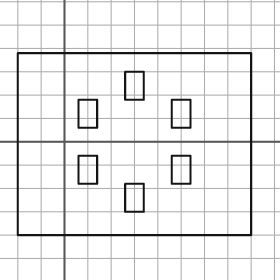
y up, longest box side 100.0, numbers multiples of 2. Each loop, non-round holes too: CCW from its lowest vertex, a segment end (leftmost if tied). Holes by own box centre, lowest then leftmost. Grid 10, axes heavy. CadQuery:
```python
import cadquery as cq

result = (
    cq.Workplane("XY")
    .moveTo(-20.0, -40.0)
    .lineTo(80.0, -40.0)
    .lineTo(80.0, 38.0)
    .lineTo(-20.0, 38.0)
    .close()
    .moveTo(26.0, -30.0)
    .lineTo(34.0, -30.0)
    .lineTo(34.0, -18.0)
    .lineTo(26.0, -18.0)
    .close()
    .moveTo(6.0, -18.0)
    .lineTo(14.0, -18.0)
    .lineTo(14.0, -6.0)
    .lineTo(6.0, -6.0)
    .close()
    .moveTo(46.0, -18.0)
    .lineTo(54.0, -18.0)
    .lineTo(54.0, -6.0)
    .lineTo(46.0, -6.0)
    .close()
    .moveTo(6.0, 6.0)
    .lineTo(14.0, 6.0)
    .lineTo(14.0, 18.0)
    .lineTo(6.0, 18.0)
    .close()
    .moveTo(46.0, 6.0)
    .lineTo(54.0, 6.0)
    .lineTo(54.0, 18.0)
    .lineTo(46.0, 18.0)
    .close()
    .moveTo(26.0, 18.0)
    .lineTo(34.0, 18.0)
    .lineTo(34.0, 30.0)
    .lineTo(26.0, 30.0)
    .close()
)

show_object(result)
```